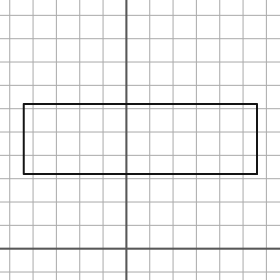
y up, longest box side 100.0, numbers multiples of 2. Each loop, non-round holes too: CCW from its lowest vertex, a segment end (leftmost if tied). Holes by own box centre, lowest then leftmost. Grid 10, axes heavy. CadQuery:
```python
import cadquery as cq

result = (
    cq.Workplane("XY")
    .moveTo(-44.0, 32.0)
    .lineTo(56.0, 32.0)
    .lineTo(56.0, 62.0)
    .lineTo(-44.0, 62.0)
    .close()
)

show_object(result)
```